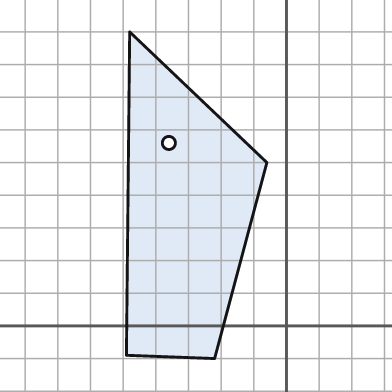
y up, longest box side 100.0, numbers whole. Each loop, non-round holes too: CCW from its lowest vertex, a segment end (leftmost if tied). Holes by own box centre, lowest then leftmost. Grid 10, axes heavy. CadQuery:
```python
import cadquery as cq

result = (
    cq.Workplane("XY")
    .moveTo(-22.0, -10.0)
    .lineTo(-6.0, 50.0)
    .lineTo(-48.0, 90.0)
    .lineTo(-49.0, -9.0)
    .close()
    .moveTo(-36.0, 56.0)
    .circle(2.0)
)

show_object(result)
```